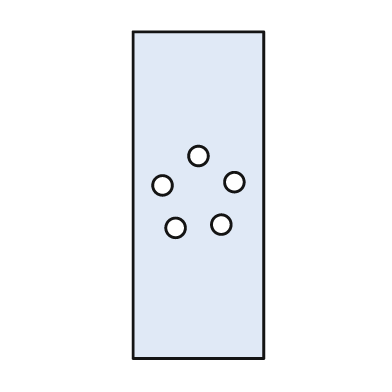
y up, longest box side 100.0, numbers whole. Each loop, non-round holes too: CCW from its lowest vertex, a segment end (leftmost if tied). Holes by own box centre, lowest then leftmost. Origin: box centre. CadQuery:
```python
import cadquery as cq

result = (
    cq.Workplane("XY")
    .moveTo(-20.0, -50.0)
    .lineTo(20.0, -50.0)
    .lineTo(20.0, 50.0)
    .lineTo(-20.0, 50.0)
    .close()
    .moveTo(-7.0, -10.0)
    .circle(3.0)
    .moveTo(7.0, -9.0)
    .circle(3.0)
    .moveTo(-11.0, 3.0)
    .circle(3.0)
    .moveTo(11.0, 4.0)
    .circle(3.0)
    .moveTo(0.0, 12.0)
    .circle(3.0)
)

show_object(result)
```